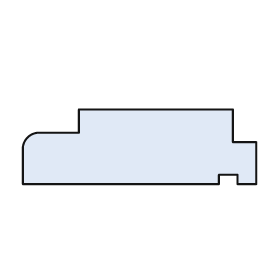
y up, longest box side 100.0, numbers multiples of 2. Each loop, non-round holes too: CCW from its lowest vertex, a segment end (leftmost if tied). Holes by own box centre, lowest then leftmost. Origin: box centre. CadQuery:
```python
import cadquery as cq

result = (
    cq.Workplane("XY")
    .moveTo(-50.0, -16.0)
    .lineTo(34.0, -16.0)
    .lineTo(34.0, -12.0)
    .lineTo(42.0, -12.0)
    .lineTo(42.0, -16.0)
    .lineTo(50.0, -16.0)
    .lineTo(50.0, 2.0)
    .lineTo(40.0, 2.0)
    .lineTo(40.0, 16.0)
    .lineTo(-26.0, 16.0)
    .lineTo(-26.0, 6.0)
    .lineTo(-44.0, 6.0)
    .threePointArc((-48.0, 4.0), (-50.0, 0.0))
    .close()
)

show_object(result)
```